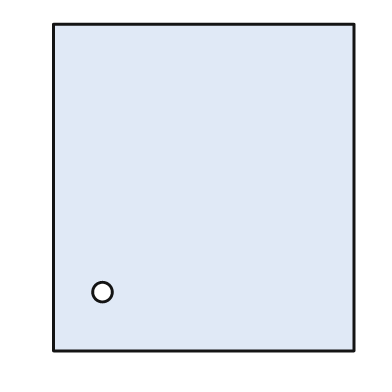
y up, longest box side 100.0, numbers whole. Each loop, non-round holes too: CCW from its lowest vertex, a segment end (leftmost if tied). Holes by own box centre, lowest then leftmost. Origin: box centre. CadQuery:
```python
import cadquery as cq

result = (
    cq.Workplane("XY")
    .moveTo(-46.0, -50.0)
    .lineTo(46.0, -50.0)
    .lineTo(46.0, 50.0)
    .lineTo(-46.0, 50.0)
    .close()
    .moveTo(-31.0, -32.0)
    .circle(3.0)
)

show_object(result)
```